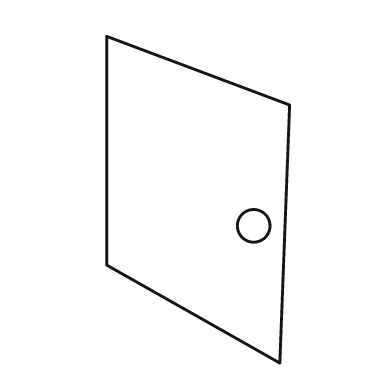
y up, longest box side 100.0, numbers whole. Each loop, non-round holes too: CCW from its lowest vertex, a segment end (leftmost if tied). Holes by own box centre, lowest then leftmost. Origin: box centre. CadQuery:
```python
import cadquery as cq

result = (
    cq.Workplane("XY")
    .moveTo(25.0, -50.0)
    .lineTo(28.0, 29.0)
    .lineTo(-28.0, 50.0)
    .lineTo(-28.0, -20.0)
    .close()
    .moveTo(17.0, -8.0)
    .circle(5.0)
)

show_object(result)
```